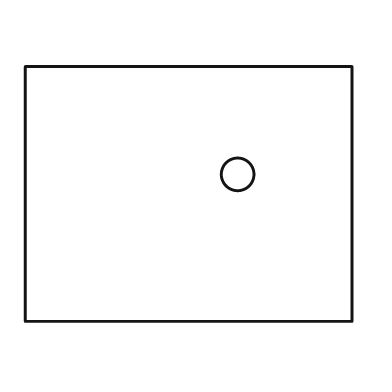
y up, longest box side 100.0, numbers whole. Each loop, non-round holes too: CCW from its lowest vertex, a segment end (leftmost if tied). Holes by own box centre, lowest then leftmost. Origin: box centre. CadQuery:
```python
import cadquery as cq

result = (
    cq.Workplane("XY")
    .moveTo(-50.0, -39.0)
    .lineTo(50.0, -39.0)
    .lineTo(50.0, 39.0)
    .lineTo(-50.0, 39.0)
    .close()
    .moveTo(15.0, 6.0)
    .circle(5.0)
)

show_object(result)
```